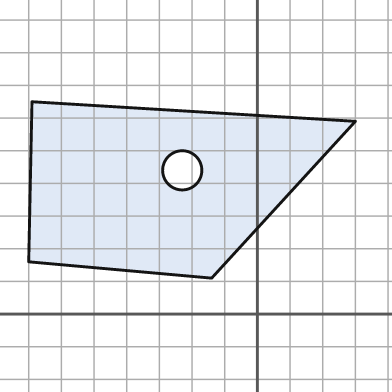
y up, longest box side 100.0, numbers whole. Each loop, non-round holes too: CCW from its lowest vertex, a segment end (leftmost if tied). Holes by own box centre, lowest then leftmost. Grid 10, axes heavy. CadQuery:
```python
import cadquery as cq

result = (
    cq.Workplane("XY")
    .moveTo(-14.0, 11.0)
    .lineTo(30.0, 59.0)
    .lineTo(-69.0, 65.0)
    .lineTo(-70.0, 16.0)
    .close()
    .moveTo(-23.0, 44.0)
    .circle(6.0)
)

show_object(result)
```